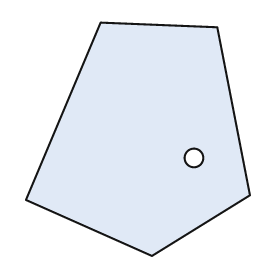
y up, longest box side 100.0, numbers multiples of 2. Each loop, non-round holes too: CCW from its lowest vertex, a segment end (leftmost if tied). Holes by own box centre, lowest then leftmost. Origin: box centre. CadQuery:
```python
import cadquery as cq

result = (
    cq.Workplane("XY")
    .moveTo(6.0, -50.0)
    .lineTo(48.0, -24.0)
    .lineTo(34.0, 48.0)
    .lineTo(-16.0, 50.0)
    .lineTo(-48.0, -26.0)
    .close()
    .moveTo(24.0, -8.0)
    .circle(4.0)
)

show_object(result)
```